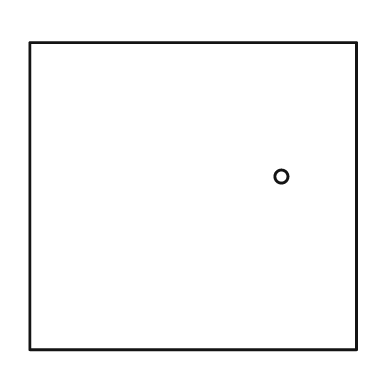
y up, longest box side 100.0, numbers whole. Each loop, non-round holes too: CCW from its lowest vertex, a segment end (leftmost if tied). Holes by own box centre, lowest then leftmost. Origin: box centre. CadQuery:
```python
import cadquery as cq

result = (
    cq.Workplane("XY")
    .moveTo(-50.0, -47.0)
    .lineTo(50.0, -47.0)
    .lineTo(50.0, 47.0)
    .lineTo(-50.0, 47.0)
    .close()
    .moveTo(27.0, 6.0)
    .circle(2.0)
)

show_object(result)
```